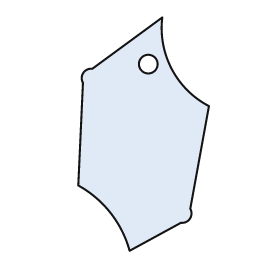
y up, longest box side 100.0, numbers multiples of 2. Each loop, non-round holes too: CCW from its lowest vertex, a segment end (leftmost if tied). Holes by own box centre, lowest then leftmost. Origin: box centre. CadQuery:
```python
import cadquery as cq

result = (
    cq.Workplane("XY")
    .moveTo(-6.0, -50.0)
    .lineTo(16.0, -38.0)
    .threePointArc((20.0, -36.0), (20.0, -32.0))
    .lineTo(28.0, 12.0)
    .threePointArc((12.0, 28.0), (8.0, 50.0))
    .lineTo(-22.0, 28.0)
    .threePointArc((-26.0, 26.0), (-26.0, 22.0))
    .lineTo(-28.0, -22.0)
    .threePointArc((-14.0, -34.0), (-6.0, -50.0))
    .close()
    .moveTo(2.0, 30.0)
    .circle(4.0)
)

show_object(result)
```